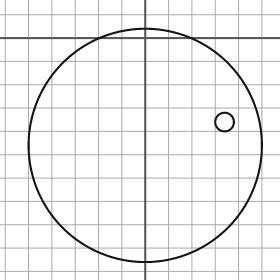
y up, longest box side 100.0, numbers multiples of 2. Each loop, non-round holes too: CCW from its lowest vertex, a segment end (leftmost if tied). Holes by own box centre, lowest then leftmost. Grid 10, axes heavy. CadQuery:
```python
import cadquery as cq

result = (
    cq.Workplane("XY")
    .moveTo(0.0, -46.0)
    .circle(50.0)
    .moveTo(34.0, -36.0)
    .circle(4.0)
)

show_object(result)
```